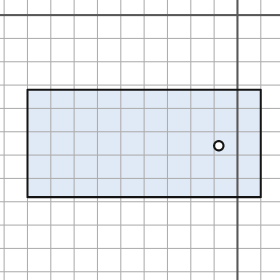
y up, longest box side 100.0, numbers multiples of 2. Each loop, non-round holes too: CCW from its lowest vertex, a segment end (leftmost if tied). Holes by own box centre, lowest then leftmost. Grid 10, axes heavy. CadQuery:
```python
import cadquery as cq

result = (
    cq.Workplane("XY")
    .moveTo(-90.0, -78.0)
    .lineTo(10.0, -78.0)
    .lineTo(10.0, -32.0)
    .lineTo(-90.0, -32.0)
    .close()
    .moveTo(-8.0, -56.0)
    .circle(2.0)
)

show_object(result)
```